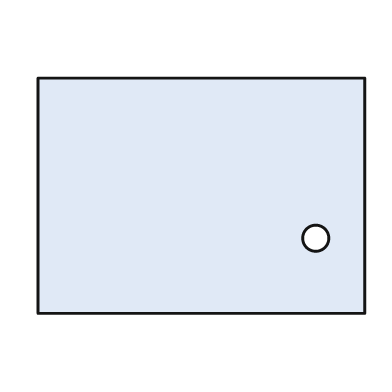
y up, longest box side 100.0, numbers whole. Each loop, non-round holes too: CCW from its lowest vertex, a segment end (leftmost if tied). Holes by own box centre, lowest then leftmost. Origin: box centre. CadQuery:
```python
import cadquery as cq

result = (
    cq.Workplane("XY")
    .moveTo(-50.0, -36.0)
    .lineTo(50.0, -36.0)
    .lineTo(50.0, 36.0)
    .lineTo(-50.0, 36.0)
    .close()
    .moveTo(35.0, -13.0)
    .circle(4.0)
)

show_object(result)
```